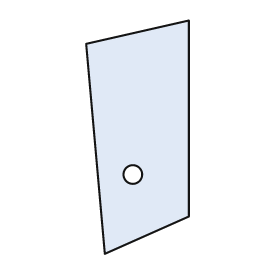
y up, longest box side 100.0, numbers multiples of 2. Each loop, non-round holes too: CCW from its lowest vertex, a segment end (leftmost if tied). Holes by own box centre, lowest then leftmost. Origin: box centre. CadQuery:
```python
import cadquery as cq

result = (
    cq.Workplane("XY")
    .moveTo(-14.0, -50.0)
    .lineTo(22.0, -34.0)
    .lineTo(22.0, 50.0)
    .lineTo(-22.0, 40.0)
    .close()
    .moveTo(-2.0, -16.0)
    .circle(4.0)
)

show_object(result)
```